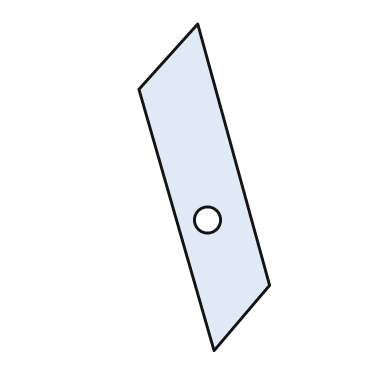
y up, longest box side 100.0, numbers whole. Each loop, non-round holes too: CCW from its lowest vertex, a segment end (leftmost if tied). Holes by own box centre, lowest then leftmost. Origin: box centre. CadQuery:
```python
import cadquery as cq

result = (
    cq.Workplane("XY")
    .moveTo(3.0, -50.0)
    .lineTo(20.0, -30.0)
    .lineTo(-2.0, 50.0)
    .lineTo(-20.0, 30.0)
    .close()
    .moveTo(1.0, -10.0)
    .circle(4.0)
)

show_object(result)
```